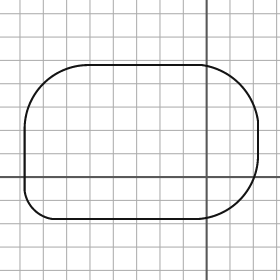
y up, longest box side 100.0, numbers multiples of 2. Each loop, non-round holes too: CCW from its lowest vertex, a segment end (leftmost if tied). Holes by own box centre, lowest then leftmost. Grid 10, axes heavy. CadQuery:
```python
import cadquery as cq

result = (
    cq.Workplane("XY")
    .moveTo(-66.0, -18.0)
    .lineTo(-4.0, -18.0)
    .threePointArc((14.0, -10.0), (22.0, 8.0))
    .lineTo(22.0, 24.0)
    .threePointArc((14.0, 40.0), (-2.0, 48.0))
    .lineTo(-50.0, 48.0)
    .threePointArc((-70.0, 40.0), (-78.0, 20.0))
    .lineTo(-78.0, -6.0)
    .threePointArc((-74.0, -14.0), (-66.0, -18.0))
    .close()
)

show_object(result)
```